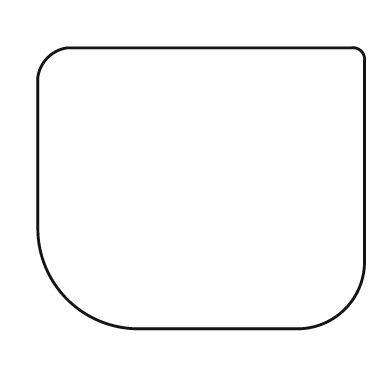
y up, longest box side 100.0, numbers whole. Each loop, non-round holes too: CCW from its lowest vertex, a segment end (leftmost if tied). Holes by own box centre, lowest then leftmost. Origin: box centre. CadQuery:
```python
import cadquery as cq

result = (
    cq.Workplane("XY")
    .moveTo(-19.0, -43.0)
    .lineTo(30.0, -43.0)
    .threePointArc((44.0, -37.0), (50.0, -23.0))
    .lineTo(50.0, 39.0)
    .threePointArc((49.0, 42.0), (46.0, 43.0))
    .lineTo(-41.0, 43.0)
    .threePointArc((-47.0, 40.0), (-50.0, 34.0))
    .lineTo(-50.0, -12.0)
    .threePointArc((-41.0, -34.0), (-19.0, -43.0))
    .close()
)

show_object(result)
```